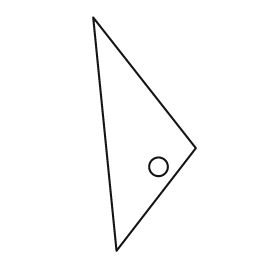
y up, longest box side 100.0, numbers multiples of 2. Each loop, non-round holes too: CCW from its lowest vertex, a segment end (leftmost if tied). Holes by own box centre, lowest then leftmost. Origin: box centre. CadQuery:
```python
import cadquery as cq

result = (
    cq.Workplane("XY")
    .moveTo(-12.0, -50.0)
    .lineTo(22.0, -6.0)
    .lineTo(-22.0, 50.0)
    .close()
    .moveTo(6.0, -14.0)
    .circle(4.0)
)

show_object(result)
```